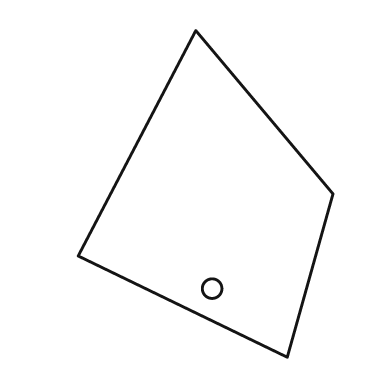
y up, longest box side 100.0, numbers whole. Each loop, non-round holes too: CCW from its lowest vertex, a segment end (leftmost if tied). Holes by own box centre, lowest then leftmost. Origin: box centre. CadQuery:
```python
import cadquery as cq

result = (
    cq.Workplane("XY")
    .moveTo(25.0, -50.0)
    .lineTo(39.0, 0.0)
    .lineTo(-3.0, 50.0)
    .lineTo(-39.0, -19.0)
    .close()
    .moveTo(2.0, -29.0)
    .circle(3.0)
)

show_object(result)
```